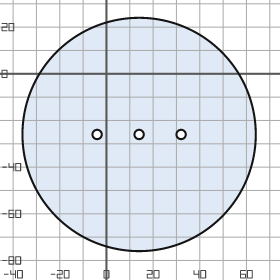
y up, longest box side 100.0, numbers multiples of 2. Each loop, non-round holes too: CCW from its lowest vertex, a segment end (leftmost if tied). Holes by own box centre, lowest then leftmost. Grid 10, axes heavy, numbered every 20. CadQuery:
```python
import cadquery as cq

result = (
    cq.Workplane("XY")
    .moveTo(14.0, -26.0)
    .circle(50.0)
    .moveTo(-4.0, -26.0)
    .circle(2.0)
    .moveTo(14.0, -26.0)
    .circle(2.0)
    .moveTo(32.0, -26.0)
    .circle(2.0)
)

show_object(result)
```